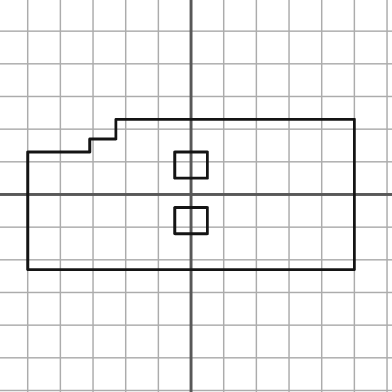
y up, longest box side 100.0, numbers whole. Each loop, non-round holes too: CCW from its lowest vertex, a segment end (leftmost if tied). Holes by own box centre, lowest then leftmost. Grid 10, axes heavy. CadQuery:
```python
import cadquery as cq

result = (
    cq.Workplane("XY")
    .moveTo(-50.0, -23.0)
    .lineTo(50.0, -23.0)
    .lineTo(50.0, 23.0)
    .lineTo(-23.0, 23.0)
    .lineTo(-23.0, 17.0)
    .lineTo(-31.0, 17.0)
    .lineTo(-31.0, 13.0)
    .lineTo(-50.0, 13.0)
    .close()
    .moveTo(-5.0, -12.0)
    .lineTo(5.0, -12.0)
    .lineTo(5.0, -4.0)
    .lineTo(-5.0, -4.0)
    .close()
    .moveTo(-5.0, 5.0)
    .lineTo(5.0, 5.0)
    .lineTo(5.0, 13.0)
    .lineTo(-5.0, 13.0)
    .close()
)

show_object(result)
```